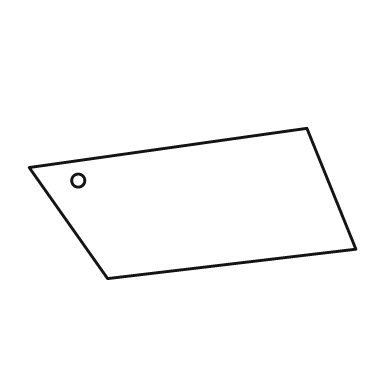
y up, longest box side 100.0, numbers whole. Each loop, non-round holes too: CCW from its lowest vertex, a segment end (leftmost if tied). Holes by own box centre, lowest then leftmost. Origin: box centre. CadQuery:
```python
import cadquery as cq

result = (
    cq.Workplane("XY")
    .moveTo(-26.0, -23.0)
    .lineTo(50.0, -14.0)
    .lineTo(35.0, 23.0)
    .lineTo(-50.0, 11.0)
    .close()
    .moveTo(-35.0, 7.0)
    .circle(2.0)
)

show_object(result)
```